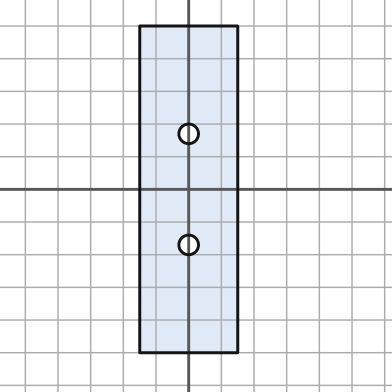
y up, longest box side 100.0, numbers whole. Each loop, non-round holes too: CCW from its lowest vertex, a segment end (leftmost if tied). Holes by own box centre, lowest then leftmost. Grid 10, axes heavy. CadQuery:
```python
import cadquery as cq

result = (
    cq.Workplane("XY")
    .moveTo(-15.0, -50.0)
    .lineTo(15.0, -50.0)
    .lineTo(15.0, 50.0)
    .lineTo(-15.0, 50.0)
    .close()
    .moveTo(0.0, -17.0)
    .circle(3.0)
    .moveTo(0.0, 17.0)
    .circle(3.0)
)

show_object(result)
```